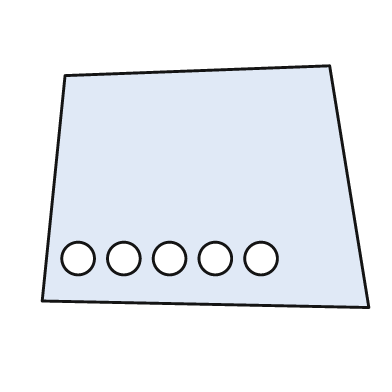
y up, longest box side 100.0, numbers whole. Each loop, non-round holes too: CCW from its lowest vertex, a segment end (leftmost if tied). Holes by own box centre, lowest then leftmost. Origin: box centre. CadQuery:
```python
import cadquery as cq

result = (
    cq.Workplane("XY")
    .moveTo(50.0, -37.0)
    .lineTo(38.0, 37.0)
    .lineTo(-43.0, 34.0)
    .lineTo(-50.0, -35.0)
    .close()
    .moveTo(-39.0, -22.0)
    .circle(5.0)
    .moveTo(-25.0, -22.0)
    .circle(5.0)
    .moveTo(-11.0, -22.0)
    .circle(5.0)
    .moveTo(3.0, -22.0)
    .circle(5.0)
    .moveTo(17.0, -22.0)
    .circle(5.0)
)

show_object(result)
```